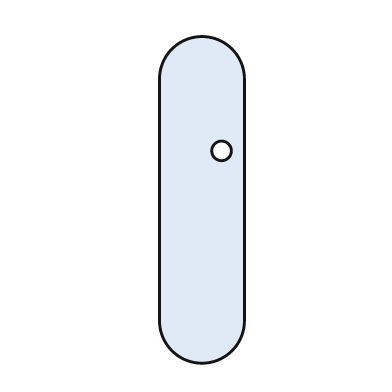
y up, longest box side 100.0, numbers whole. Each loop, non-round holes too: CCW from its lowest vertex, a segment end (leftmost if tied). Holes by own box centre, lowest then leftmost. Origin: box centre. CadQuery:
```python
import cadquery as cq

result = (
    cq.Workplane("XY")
    .moveTo(-13.0, -37.0)
    .threePointArc((0.0, -50.0), (13.0, -37.0))
    .lineTo(13.0, 37.0)
    .threePointArc((0.0, 50.0), (-13.0, 37.0))
    .close()
    .moveTo(6.0, 15.0)
    .circle(3.0)
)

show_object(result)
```